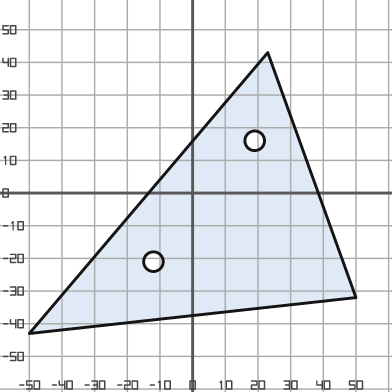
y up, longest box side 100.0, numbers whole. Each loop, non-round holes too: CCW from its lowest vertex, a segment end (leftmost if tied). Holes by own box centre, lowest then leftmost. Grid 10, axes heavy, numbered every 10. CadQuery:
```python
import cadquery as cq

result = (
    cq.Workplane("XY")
    .moveTo(-50.0, -43.0)
    .lineTo(50.0, -32.0)
    .lineTo(23.0, 43.0)
    .close()
    .moveTo(-12.0, -21.0)
    .circle(3.0)
    .moveTo(19.0, 16.0)
    .circle(3.0)
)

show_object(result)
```